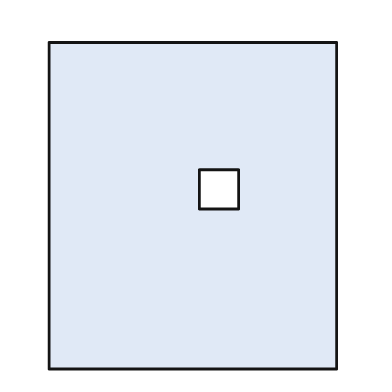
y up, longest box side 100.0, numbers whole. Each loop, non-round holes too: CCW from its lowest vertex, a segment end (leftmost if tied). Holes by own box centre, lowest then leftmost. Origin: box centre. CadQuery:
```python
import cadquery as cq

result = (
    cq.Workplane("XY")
    .moveTo(-44.0, -50.0)
    .lineTo(44.0, -50.0)
    .lineTo(44.0, 50.0)
    .lineTo(-44.0, 50.0)
    .close()
    .moveTo(2.0, -1.0)
    .lineTo(14.0, -1.0)
    .lineTo(14.0, 11.0)
    .lineTo(2.0, 11.0)
    .close()
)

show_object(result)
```